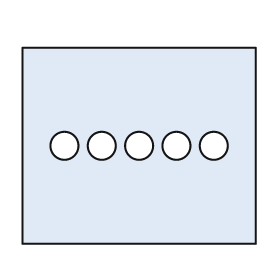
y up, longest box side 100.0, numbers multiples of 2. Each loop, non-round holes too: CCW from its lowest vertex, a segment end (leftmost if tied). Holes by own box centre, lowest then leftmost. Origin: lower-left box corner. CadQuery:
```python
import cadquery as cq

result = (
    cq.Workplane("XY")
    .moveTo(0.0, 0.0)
    .lineTo(100.0, 0.0)
    .lineTo(100.0, 84.0)
    .lineTo(0.0, 84.0)
    .close()
    .moveTo(18.0, 42.0)
    .circle(6.0)
    .moveTo(34.0, 42.0)
    .circle(6.0)
    .moveTo(50.0, 42.0)
    .circle(6.0)
    .moveTo(66.0, 42.0)
    .circle(6.0)
    .moveTo(82.0, 42.0)
    .circle(6.0)
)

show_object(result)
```